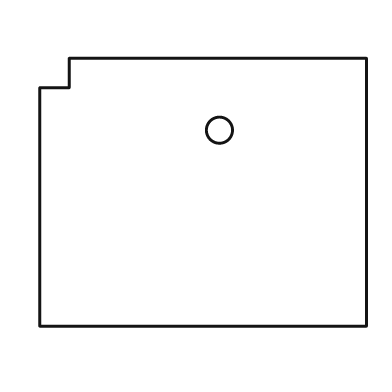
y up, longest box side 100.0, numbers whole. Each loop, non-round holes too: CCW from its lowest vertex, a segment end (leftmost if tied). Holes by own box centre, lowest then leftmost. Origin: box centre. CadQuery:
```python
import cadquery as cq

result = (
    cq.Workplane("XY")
    .moveTo(-50.0, -41.0)
    .lineTo(50.0, -41.0)
    .lineTo(50.0, 41.0)
    .lineTo(-41.0, 41.0)
    .lineTo(-41.0, 32.0)
    .lineTo(-50.0, 32.0)
    .close()
    .moveTo(5.0, 19.0)
    .circle(4.0)
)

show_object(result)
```